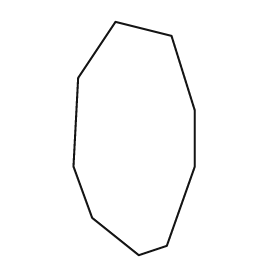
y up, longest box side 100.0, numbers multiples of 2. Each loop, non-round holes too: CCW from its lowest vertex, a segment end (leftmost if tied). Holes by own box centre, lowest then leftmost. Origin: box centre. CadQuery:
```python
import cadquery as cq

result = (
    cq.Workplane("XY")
    .moveTo(2.0, -50.0)
    .lineTo(14.0, -46.0)
    .lineTo(26.0, -12.0)
    .lineTo(26.0, 12.0)
    .lineTo(16.0, 44.0)
    .lineTo(-8.0, 50.0)
    .lineTo(-24.0, 26.0)
    .lineTo(-26.0, -12.0)
    .lineTo(-18.0, -34.0)
    .close()
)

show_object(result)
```